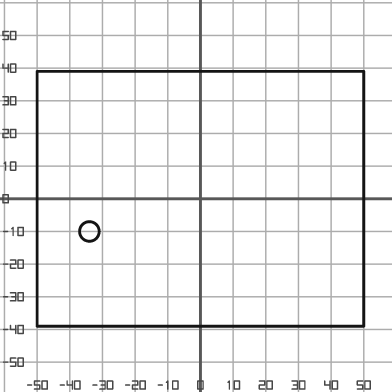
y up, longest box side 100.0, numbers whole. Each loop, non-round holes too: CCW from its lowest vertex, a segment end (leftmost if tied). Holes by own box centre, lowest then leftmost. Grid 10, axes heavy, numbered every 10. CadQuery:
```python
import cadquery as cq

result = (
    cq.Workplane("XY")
    .moveTo(-50.0, -39.0)
    .lineTo(50.0, -39.0)
    .lineTo(50.0, 39.0)
    .lineTo(-50.0, 39.0)
    .close()
    .moveTo(-34.0, -10.0)
    .circle(3.0)
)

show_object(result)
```